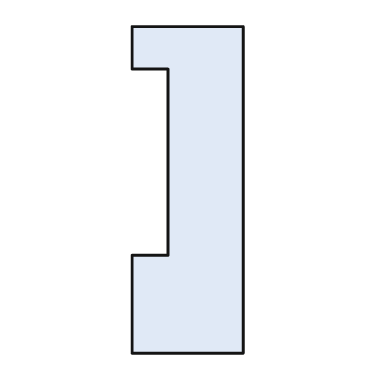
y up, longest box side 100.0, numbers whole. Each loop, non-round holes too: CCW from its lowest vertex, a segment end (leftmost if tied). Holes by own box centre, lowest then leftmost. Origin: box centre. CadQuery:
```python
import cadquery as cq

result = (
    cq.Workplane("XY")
    .moveTo(-17.0, -50.0)
    .lineTo(17.0, -50.0)
    .lineTo(17.0, 50.0)
    .lineTo(-17.0, 50.0)
    .lineTo(-17.0, 37.0)
    .lineTo(-6.0, 37.0)
    .lineTo(-6.0, -20.0)
    .lineTo(-17.0, -20.0)
    .close()
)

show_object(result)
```